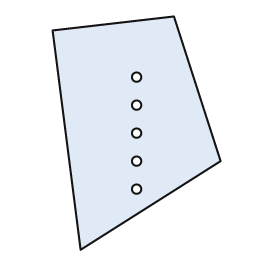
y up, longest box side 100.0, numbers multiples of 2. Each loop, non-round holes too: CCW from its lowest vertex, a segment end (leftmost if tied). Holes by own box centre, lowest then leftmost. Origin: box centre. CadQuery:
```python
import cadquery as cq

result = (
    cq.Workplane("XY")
    .moveTo(-24.0, -50.0)
    .lineTo(36.0, -12.0)
    .lineTo(16.0, 50.0)
    .lineTo(-36.0, 44.0)
    .close()
    .moveTo(0.0, -24.0)
    .circle(2.0)
    .moveTo(0.0, -12.0)
    .circle(2.0)
    .moveTo(0.0, 0.0)
    .circle(2.0)
    .moveTo(0.0, 12.0)
    .circle(2.0)
    .moveTo(0.0, 24.0)
    .circle(2.0)
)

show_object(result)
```